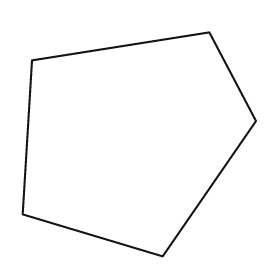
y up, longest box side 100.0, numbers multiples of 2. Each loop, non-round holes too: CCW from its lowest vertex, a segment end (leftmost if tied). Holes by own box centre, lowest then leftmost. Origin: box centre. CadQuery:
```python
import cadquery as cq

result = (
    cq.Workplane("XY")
    .moveTo(10.0, -48.0)
    .lineTo(50.0, 10.0)
    .lineTo(30.0, 48.0)
    .lineTo(-46.0, 36.0)
    .lineTo(-50.0, -30.0)
    .close()
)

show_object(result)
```